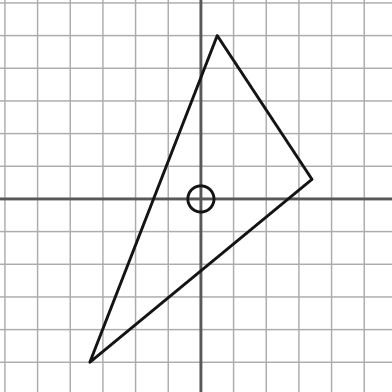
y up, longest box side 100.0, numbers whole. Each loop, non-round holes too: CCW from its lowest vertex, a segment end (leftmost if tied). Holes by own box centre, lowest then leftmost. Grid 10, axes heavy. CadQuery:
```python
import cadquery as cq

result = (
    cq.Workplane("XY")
    .moveTo(-34.0, -50.0)
    .lineTo(34.0, 6.0)
    .lineTo(5.0, 50.0)
    .close()
    .moveTo(0.0, 0.0)
    .circle(4.0)
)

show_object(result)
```